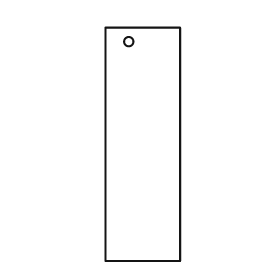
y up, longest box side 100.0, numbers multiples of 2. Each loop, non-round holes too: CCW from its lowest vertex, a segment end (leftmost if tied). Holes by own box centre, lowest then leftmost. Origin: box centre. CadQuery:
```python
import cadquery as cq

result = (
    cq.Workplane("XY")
    .moveTo(-16.0, -50.0)
    .lineTo(16.0, -50.0)
    .lineTo(16.0, 50.0)
    .lineTo(-16.0, 50.0)
    .close()
    .moveTo(-6.0, 44.0)
    .circle(2.0)
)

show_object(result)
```